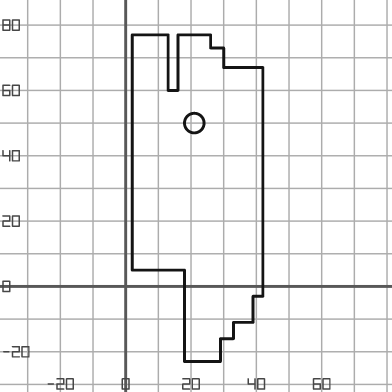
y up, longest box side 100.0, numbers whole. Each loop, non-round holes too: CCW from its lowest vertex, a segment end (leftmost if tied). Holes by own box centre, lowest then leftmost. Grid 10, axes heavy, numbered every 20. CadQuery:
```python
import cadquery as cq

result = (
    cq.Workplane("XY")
    .moveTo(18.0, -23.0)
    .lineTo(29.0, -23.0)
    .lineTo(29.0, -16.0)
    .lineTo(33.0, -16.0)
    .lineTo(33.0, -11.0)
    .lineTo(39.0, -11.0)
    .lineTo(39.0, -3.0)
    .lineTo(42.0, -3.0)
    .lineTo(42.0, 67.0)
    .lineTo(30.0, 67.0)
    .lineTo(30.0, 73.0)
    .lineTo(26.0, 73.0)
    .lineTo(26.0, 77.0)
    .lineTo(16.0, 77.0)
    .lineTo(16.0, 60.0)
    .lineTo(13.0, 60.0)
    .lineTo(13.0, 77.0)
    .lineTo(2.0, 77.0)
    .lineTo(2.0, 5.0)
    .lineTo(18.0, 5.0)
    .close()
    .moveTo(21.0, 50.0)
    .circle(3.0)
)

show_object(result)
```